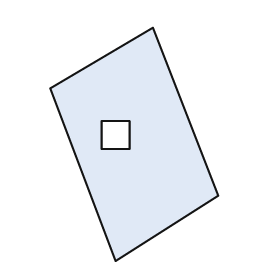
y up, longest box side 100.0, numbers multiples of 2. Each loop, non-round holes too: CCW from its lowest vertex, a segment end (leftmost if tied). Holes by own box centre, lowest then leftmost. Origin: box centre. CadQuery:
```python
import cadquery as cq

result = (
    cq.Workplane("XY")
    .moveTo(-8.0, -50.0)
    .lineTo(36.0, -22.0)
    .lineTo(8.0, 50.0)
    .lineTo(-36.0, 24.0)
    .close()
    .moveTo(-14.0, -2.0)
    .lineTo(-2.0, -2.0)
    .lineTo(-2.0, 10.0)
    .lineTo(-14.0, 10.0)
    .close()
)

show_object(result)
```